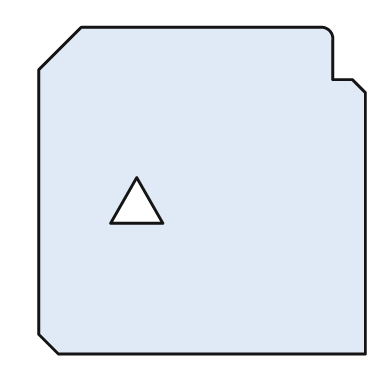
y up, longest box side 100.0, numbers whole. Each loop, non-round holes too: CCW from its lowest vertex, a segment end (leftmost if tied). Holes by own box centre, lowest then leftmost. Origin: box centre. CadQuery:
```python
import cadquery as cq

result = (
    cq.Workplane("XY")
    .moveTo(-44.0, -50.0)
    .lineTo(50.0, -50.0)
    .lineTo(50.0, 30.0)
    .lineTo(46.0, 34.0)
    .lineTo(40.0, 34.0)
    .lineTo(40.0, 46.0)
    .threePointArc((39.0, 49.0), (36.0, 50.0))
    .lineTo(-37.0, 50.0)
    .lineTo(-50.0, 37.0)
    .lineTo(-50.0, -44.0)
    .close()
    .moveTo(-28.0, -10.0)
    .lineTo(-12.0, -10.0)
    .lineTo(-20.0, 4.0)
    .close()
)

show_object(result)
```